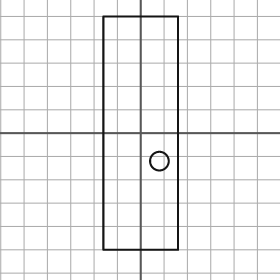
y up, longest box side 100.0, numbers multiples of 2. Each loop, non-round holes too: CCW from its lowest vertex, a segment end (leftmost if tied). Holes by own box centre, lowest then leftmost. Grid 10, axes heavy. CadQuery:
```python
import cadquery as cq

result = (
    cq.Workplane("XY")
    .moveTo(-16.0, -50.0)
    .lineTo(16.0, -50.0)
    .lineTo(16.0, 50.0)
    .lineTo(-16.0, 50.0)
    .close()
    .moveTo(8.0, -12.0)
    .circle(4.0)
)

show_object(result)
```